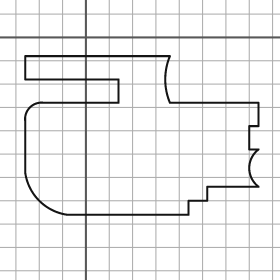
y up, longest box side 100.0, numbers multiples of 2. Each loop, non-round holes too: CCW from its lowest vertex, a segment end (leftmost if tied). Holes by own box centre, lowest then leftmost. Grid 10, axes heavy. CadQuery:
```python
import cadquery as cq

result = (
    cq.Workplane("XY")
    .moveTo(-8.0, -76.0)
    .lineTo(44.0, -76.0)
    .lineTo(44.0, -70.0)
    .lineTo(52.0, -70.0)
    .lineTo(52.0, -64.0)
    .lineTo(74.0, -64.0)
    .threePointArc((70.0, -56.0), (74.0, -48.0))
    .lineTo(70.0, -48.0)
    .lineTo(70.0, -38.0)
    .lineTo(74.0, -38.0)
    .lineTo(74.0, -28.0)
    .lineTo(36.0, -28.0)
    .threePointArc((34.0, -18.0), (36.0, -8.0))
    .lineTo(-26.0, -8.0)
    .lineTo(-26.0, -18.0)
    .lineTo(14.0, -18.0)
    .lineTo(14.0, -28.0)
    .lineTo(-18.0, -28.0)
    .threePointArc((-24.0, -30.0), (-26.0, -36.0))
    .lineTo(-26.0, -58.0)
    .threePointArc((-20.0, -70.0), (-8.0, -76.0))
    .close()
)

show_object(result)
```